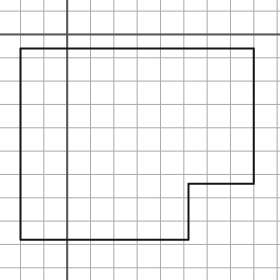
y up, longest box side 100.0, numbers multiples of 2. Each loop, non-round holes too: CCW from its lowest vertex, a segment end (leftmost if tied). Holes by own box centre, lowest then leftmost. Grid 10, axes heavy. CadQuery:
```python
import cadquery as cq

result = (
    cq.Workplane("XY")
    .moveTo(-20.0, -88.0)
    .lineTo(52.0, -88.0)
    .lineTo(52.0, -64.0)
    .lineTo(80.0, -64.0)
    .lineTo(80.0, -6.0)
    .lineTo(-20.0, -6.0)
    .close()
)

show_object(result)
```